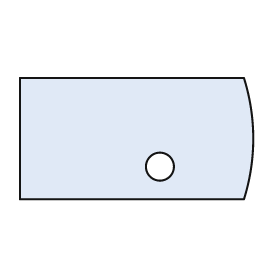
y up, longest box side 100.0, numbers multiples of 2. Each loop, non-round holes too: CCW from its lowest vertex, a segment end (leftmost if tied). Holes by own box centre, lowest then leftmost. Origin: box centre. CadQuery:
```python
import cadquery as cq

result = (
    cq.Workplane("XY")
    .moveTo(-50.0, -26.0)
    .lineTo(46.0, -26.0)
    .threePointArc((50.0, 0.0), (46.0, 26.0))
    .lineTo(-50.0, 26.0)
    .close()
    .moveTo(10.0, -12.0)
    .circle(6.0)
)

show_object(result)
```